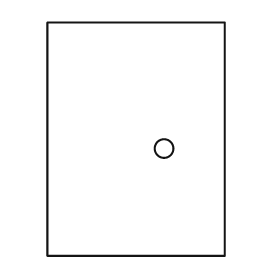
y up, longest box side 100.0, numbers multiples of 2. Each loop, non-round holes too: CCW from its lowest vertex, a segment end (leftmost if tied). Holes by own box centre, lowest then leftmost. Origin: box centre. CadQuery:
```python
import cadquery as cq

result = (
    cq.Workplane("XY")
    .moveTo(-38.0, -50.0)
    .lineTo(38.0, -50.0)
    .lineTo(38.0, 50.0)
    .lineTo(-38.0, 50.0)
    .close()
    .moveTo(12.0, -4.0)
    .circle(4.0)
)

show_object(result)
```